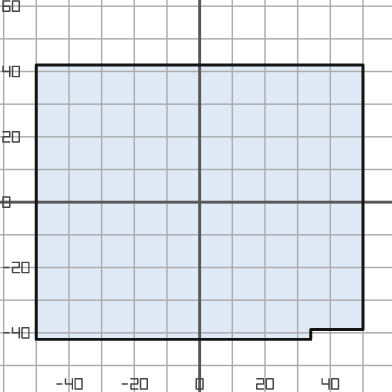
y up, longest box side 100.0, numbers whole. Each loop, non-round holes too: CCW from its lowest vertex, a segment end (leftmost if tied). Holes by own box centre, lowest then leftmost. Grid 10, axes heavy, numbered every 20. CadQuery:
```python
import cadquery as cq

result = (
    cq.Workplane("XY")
    .moveTo(-50.0, -42.0)
    .lineTo(34.0, -42.0)
    .lineTo(34.0, -39.0)
    .lineTo(50.0, -39.0)
    .lineTo(50.0, 42.0)
    .lineTo(-50.0, 42.0)
    .close()
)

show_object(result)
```